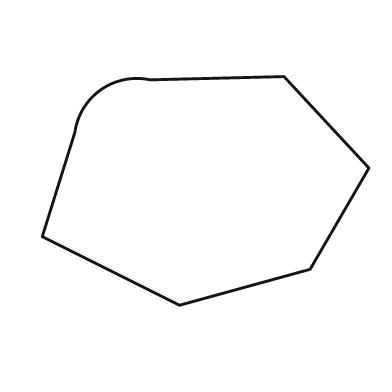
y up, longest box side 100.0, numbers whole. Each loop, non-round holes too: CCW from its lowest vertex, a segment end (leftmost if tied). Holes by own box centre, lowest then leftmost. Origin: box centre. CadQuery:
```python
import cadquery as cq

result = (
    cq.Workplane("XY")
    .moveTo(-8.0, -35.0)
    .lineTo(32.0, -24.0)
    .lineTo(50.0, 7.0)
    .lineTo(24.0, 35.0)
    .lineTo(-17.0, 34.0)
    .threePointArc((-32.0, 31.0), (-40.0, 18.0))
    .lineTo(-50.0, -14.0)
    .close()
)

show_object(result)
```